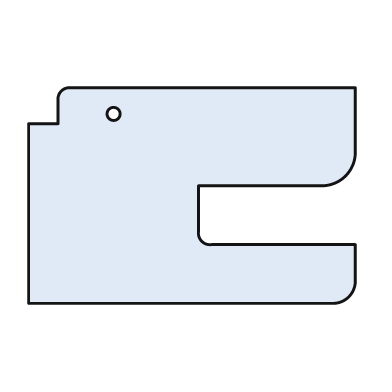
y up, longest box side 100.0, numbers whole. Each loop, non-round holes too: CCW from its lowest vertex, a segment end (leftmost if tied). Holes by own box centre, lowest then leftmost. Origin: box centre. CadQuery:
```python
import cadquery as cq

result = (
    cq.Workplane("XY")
    .moveTo(-50.0, -33.0)
    .lineTo(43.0, -33.0)
    .threePointArc((48.0, -31.0), (50.0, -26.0))
    .lineTo(50.0, -15.0)
    .lineTo(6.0, -15.0)
    .threePointArc((3.0, -14.0), (2.0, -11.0))
    .lineTo(2.0, 3.0)
    .lineTo(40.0, 3.0)
    .threePointArc((47.0, 6.0), (50.0, 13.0))
    .lineTo(50.0, 33.0)
    .lineTo(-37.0, 33.0)
    .threePointArc((-40.0, 32.0), (-41.0, 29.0))
    .lineTo(-41.0, 22.0)
    .lineTo(-50.0, 22.0)
    .close()
    .moveTo(-24.0, 25.0)
    .circle(2.0)
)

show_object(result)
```